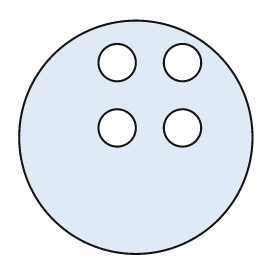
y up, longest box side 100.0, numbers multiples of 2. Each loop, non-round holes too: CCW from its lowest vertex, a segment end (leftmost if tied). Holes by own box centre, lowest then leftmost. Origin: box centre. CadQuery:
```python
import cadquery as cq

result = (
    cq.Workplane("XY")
    .moveTo(0.0, 0.0)
    .circle(50.0)
    .moveTo(-8.0, 4.0)
    .circle(8.0)
    .moveTo(20.0, 4.0)
    .circle(8.0)
    .moveTo(-8.0, 32.0)
    .circle(8.0)
    .moveTo(20.0, 32.0)
    .circle(8.0)
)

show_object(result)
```